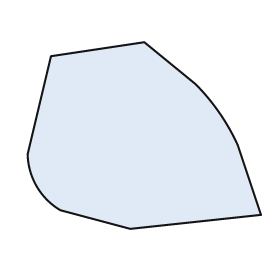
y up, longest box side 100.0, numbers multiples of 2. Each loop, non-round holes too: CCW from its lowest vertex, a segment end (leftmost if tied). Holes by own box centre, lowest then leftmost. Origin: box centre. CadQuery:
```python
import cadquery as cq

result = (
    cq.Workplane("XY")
    .moveTo(-6.0, -40.0)
    .lineTo(50.0, -34.0)
    .lineTo(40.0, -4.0)
    .threePointArc((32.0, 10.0), (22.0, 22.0))
    .lineTo(0.0, 40.0)
    .lineTo(-40.0, 34.0)
    .lineTo(-50.0, -8.0)
    .threePointArc((-46.0, -22.0), (-36.0, -32.0))
    .close()
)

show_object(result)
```